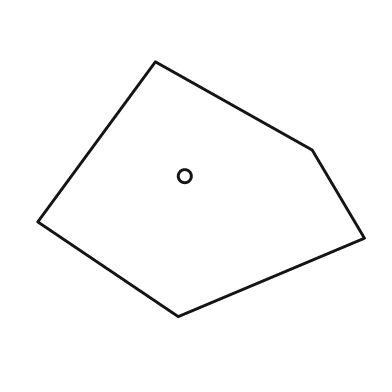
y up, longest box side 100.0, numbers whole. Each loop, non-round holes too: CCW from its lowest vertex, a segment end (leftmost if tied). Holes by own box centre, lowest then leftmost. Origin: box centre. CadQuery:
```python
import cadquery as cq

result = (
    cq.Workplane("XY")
    .moveTo(-7.0, -39.0)
    .lineTo(50.0, -15.0)
    .lineTo(34.0, 12.0)
    .lineTo(-14.0, 39.0)
    .lineTo(-50.0, -10.0)
    .close()
    .moveTo(-5.0, 4.0)
    .circle(2.0)
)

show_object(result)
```